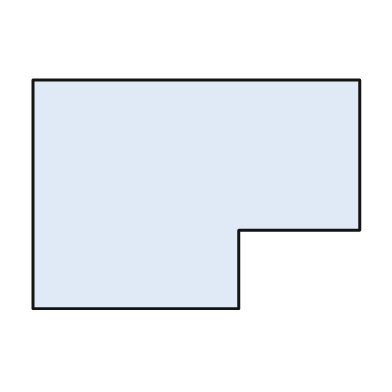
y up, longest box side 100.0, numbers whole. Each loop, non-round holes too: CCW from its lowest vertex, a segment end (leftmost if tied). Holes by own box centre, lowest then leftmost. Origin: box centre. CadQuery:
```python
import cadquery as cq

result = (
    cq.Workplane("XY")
    .moveTo(-50.0, -35.0)
    .lineTo(13.0, -35.0)
    .lineTo(13.0, -11.0)
    .lineTo(50.0, -11.0)
    .lineTo(50.0, 35.0)
    .lineTo(-50.0, 35.0)
    .close()
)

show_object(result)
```